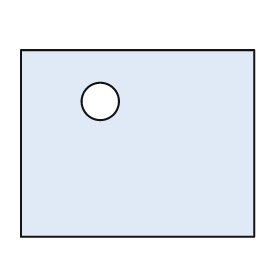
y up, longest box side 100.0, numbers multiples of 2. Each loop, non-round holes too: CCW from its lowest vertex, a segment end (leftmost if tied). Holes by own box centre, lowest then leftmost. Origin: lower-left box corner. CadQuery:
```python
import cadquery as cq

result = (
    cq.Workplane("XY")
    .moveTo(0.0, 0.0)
    .lineTo(100.0, 0.0)
    .lineTo(100.0, 80.0)
    .lineTo(0.0, 80.0)
    .close()
    .moveTo(34.0, 58.0)
    .circle(8.0)
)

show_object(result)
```